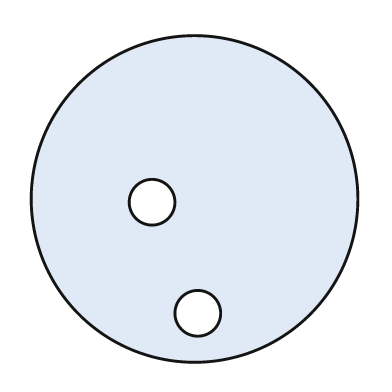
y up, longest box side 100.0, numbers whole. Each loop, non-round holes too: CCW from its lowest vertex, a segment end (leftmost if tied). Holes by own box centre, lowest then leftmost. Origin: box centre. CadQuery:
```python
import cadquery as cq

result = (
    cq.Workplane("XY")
    .moveTo(0.0, 0.0)
    .circle(50.0)
    .moveTo(1.0, -35.0)
    .circle(7.0)
    .moveTo(-13.0, -1.0)
    .circle(7.0)
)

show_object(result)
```